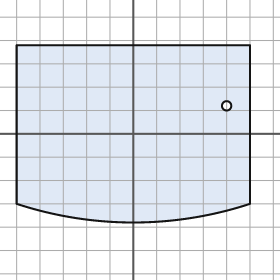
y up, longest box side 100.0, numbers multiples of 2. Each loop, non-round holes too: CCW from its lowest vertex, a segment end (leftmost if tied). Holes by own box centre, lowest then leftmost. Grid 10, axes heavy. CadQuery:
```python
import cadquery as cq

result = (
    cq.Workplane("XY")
    .moveTo(-50.0, -30.0)
    .threePointArc((0.0, -38.0), (50.0, -30.0))
    .lineTo(50.0, 38.0)
    .lineTo(-50.0, 38.0)
    .close()
    .moveTo(40.0, 12.0)
    .circle(2.0)
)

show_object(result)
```